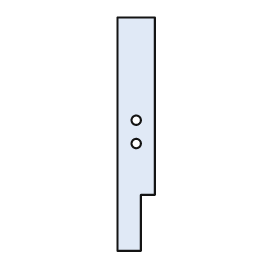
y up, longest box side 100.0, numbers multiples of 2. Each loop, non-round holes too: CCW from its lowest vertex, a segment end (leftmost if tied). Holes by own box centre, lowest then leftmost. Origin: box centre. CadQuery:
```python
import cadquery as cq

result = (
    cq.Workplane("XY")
    .moveTo(-8.0, -50.0)
    .lineTo(2.0, -50.0)
    .lineTo(2.0, -26.0)
    .lineTo(8.0, -26.0)
    .lineTo(8.0, 50.0)
    .lineTo(-8.0, 50.0)
    .close()
    .moveTo(0.0, -4.0)
    .circle(2.0)
    .moveTo(0.0, 6.0)
    .circle(2.0)
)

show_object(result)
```